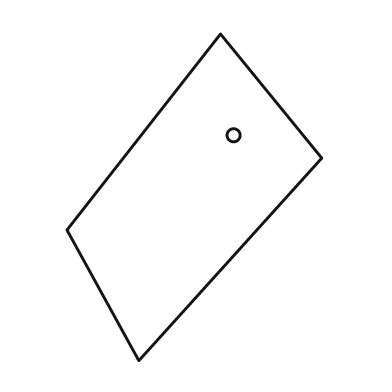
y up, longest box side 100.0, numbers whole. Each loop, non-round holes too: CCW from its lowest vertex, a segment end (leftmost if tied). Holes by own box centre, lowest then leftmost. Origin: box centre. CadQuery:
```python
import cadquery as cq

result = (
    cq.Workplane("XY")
    .moveTo(-17.0, -50.0)
    .lineTo(39.0, 12.0)
    .lineTo(8.0, 50.0)
    .lineTo(-39.0, -10.0)
    .close()
    .moveTo(12.0, 19.0)
    .circle(2.0)
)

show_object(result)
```